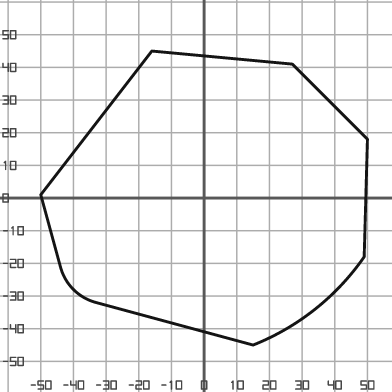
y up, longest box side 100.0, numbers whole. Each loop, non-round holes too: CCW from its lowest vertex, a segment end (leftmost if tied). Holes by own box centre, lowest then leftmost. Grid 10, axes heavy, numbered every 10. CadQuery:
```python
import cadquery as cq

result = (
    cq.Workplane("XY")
    .moveTo(15.0, -45.0)
    .threePointArc((34.0, -34.0), (49.0, -18.0))
    .lineTo(50.0, 18.0)
    .lineTo(27.0, 41.0)
    .lineTo(-16.0, 45.0)
    .lineTo(-50.0, 1.0)
    .lineTo(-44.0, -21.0)
    .threePointArc((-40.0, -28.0), (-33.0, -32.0))
    .close()
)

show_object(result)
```